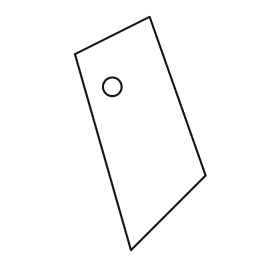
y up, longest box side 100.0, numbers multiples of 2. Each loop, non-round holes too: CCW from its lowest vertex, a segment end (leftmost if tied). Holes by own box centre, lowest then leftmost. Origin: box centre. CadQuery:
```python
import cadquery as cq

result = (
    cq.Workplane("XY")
    .moveTo(-4.0, -50.0)
    .lineTo(28.0, -18.0)
    .lineTo(4.0, 50.0)
    .lineTo(-28.0, 34.0)
    .close()
    .moveTo(-12.0, 20.0)
    .circle(4.0)
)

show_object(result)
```